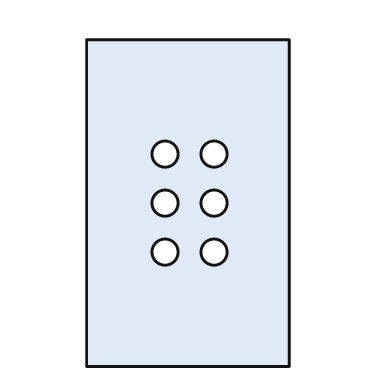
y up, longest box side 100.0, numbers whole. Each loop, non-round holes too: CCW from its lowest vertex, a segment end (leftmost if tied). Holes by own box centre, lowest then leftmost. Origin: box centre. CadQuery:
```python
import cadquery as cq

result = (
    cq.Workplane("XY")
    .moveTo(-31.0, -50.0)
    .lineTo(31.0, -50.0)
    .lineTo(31.0, 50.0)
    .lineTo(-31.0, 50.0)
    .close()
    .moveTo(-7.0, -15.0)
    .circle(4.0)
    .moveTo(8.0, -15.0)
    .circle(4.0)
    .moveTo(-7.0, 0.0)
    .circle(4.0)
    .moveTo(8.0, 0.0)
    .circle(4.0)
    .moveTo(-7.0, 15.0)
    .circle(4.0)
    .moveTo(8.0, 15.0)
    .circle(4.0)
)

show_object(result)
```